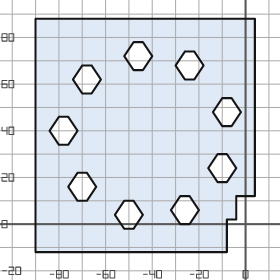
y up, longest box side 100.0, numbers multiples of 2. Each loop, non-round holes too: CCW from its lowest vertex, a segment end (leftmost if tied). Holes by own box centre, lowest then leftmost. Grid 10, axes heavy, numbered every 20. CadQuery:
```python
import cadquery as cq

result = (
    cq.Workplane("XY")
    .moveTo(-90.0, -12.0)
    .lineTo(-8.0, -12.0)
    .lineTo(-8.0, 2.0)
    .lineTo(-4.0, 2.0)
    .lineTo(-4.0, 12.0)
    .lineTo(4.0, 12.0)
    .lineTo(4.0, 88.0)
    .lineTo(-90.0, 88.0)
    .close()
    .moveTo(-52.0, -2.0)
    .lineTo(-48.0, -2.0)
    .lineTo(-44.0, 4.0)
    .lineTo(-48.0, 10.0)
    .lineTo(-52.0, 10.0)
    .lineTo(-56.0, 4.0)
    .close()
    .moveTo(-28.0, 0.0)
    .lineTo(-24.0, 0.0)
    .lineTo(-20.0, 6.0)
    .lineTo(-24.0, 12.0)
    .lineTo(-28.0, 12.0)
    .lineTo(-32.0, 6.0)
    .close()
    .moveTo(-72.0, 10.0)
    .lineTo(-68.0, 10.0)
    .lineTo(-64.0, 16.0)
    .lineTo(-68.0, 22.0)
    .lineTo(-72.0, 22.0)
    .lineTo(-76.0, 16.0)
    .close()
    .moveTo(-12.0, 18.0)
    .lineTo(-8.0, 18.0)
    .lineTo(-4.0, 24.0)
    .lineTo(-8.0, 30.0)
    .lineTo(-12.0, 30.0)
    .lineTo(-16.0, 24.0)
    .close()
    .moveTo(-80.0, 34.0)
    .lineTo(-76.0, 34.0)
    .lineTo(-72.0, 40.0)
    .lineTo(-76.0, 46.0)
    .lineTo(-80.0, 46.0)
    .lineTo(-84.0, 40.0)
    .close()
    .moveTo(-10.0, 42.0)
    .lineTo(-6.0, 42.0)
    .lineTo(-2.0, 48.0)
    .lineTo(-6.0, 54.0)
    .lineTo(-10.0, 54.0)
    .lineTo(-14.0, 48.0)
    .close()
    .moveTo(-70.0, 56.0)
    .lineTo(-66.0, 56.0)
    .lineTo(-62.0, 62.0)
    .lineTo(-66.0, 68.0)
    .lineTo(-70.0, 68.0)
    .lineTo(-74.0, 62.0)
    .close()
    .moveTo(-26.0, 62.0)
    .lineTo(-22.0, 62.0)
    .lineTo(-18.0, 68.0)
    .lineTo(-22.0, 74.0)
    .lineTo(-26.0, 74.0)
    .lineTo(-30.0, 68.0)
    .close()
    .moveTo(-48.0, 66.0)
    .lineTo(-44.0, 66.0)
    .lineTo(-40.0, 72.0)
    .lineTo(-44.0, 78.0)
    .lineTo(-48.0, 78.0)
    .lineTo(-52.0, 72.0)
    .close()
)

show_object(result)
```